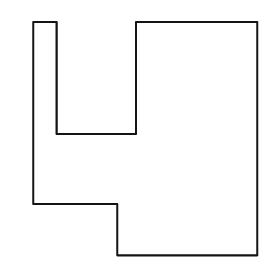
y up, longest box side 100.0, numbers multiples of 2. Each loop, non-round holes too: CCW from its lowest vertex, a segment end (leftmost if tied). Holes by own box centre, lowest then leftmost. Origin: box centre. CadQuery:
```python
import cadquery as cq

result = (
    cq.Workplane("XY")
    .moveTo(-12.0, -50.0)
    .lineTo(48.0, -50.0)
    .lineTo(48.0, 50.0)
    .lineTo(-4.0, 50.0)
    .lineTo(-4.0, 2.0)
    .lineTo(-38.0, 2.0)
    .lineTo(-38.0, 50.0)
    .lineTo(-48.0, 50.0)
    .lineTo(-48.0, -28.0)
    .lineTo(-12.0, -28.0)
    .close()
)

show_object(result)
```